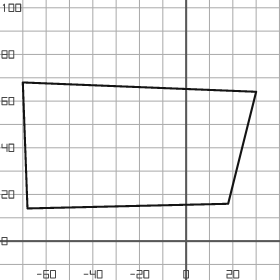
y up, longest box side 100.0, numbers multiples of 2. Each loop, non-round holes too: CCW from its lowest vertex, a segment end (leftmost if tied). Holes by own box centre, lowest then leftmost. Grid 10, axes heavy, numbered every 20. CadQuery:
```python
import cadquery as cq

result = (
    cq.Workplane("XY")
    .moveTo(-68.0, 14.0)
    .lineTo(18.0, 16.0)
    .lineTo(30.0, 64.0)
    .lineTo(-70.0, 68.0)
    .close()
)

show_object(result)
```